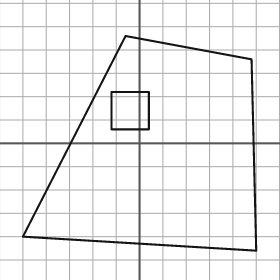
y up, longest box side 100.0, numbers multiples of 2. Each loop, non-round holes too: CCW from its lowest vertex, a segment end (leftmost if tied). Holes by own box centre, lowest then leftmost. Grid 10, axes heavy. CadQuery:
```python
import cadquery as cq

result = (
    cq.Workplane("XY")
    .moveTo(50.0, -46.0)
    .lineTo(48.0, 36.0)
    .lineTo(-6.0, 46.0)
    .lineTo(-50.0, -40.0)
    .close()
    .moveTo(-12.0, 6.0)
    .lineTo(4.0, 6.0)
    .lineTo(4.0, 22.0)
    .lineTo(-12.0, 22.0)
    .close()
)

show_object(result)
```